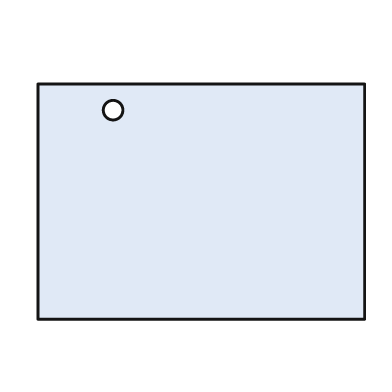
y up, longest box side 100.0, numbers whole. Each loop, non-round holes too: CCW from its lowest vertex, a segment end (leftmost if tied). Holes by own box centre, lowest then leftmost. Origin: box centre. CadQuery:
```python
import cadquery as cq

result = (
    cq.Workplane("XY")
    .moveTo(-50.0, -36.0)
    .lineTo(50.0, -36.0)
    .lineTo(50.0, 36.0)
    .lineTo(-50.0, 36.0)
    .close()
    .moveTo(-27.0, 28.0)
    .circle(3.0)
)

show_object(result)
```